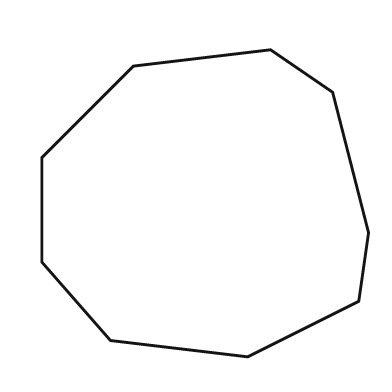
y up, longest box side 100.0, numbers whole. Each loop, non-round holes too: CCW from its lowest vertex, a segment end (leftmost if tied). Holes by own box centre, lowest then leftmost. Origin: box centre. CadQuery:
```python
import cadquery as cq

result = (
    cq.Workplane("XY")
    .moveTo(13.0, -47.0)
    .lineTo(47.0, -30.0)
    .lineTo(50.0, -9.0)
    .lineTo(39.0, 34.0)
    .lineTo(20.0, 47.0)
    .lineTo(-22.0, 42.0)
    .lineTo(-50.0, 14.0)
    .lineTo(-50.0, -18.0)
    .lineTo(-29.0, -42.0)
    .close()
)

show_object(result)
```